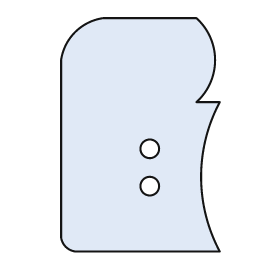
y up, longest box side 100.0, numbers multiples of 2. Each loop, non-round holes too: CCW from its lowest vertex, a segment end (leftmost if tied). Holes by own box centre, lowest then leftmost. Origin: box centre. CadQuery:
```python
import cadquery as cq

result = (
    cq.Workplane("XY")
    .moveTo(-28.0, -50.0)
    .lineTo(34.0, -50.0)
    .threePointArc((26.0, -18.0), (34.0, 14.0))
    .lineTo(24.0, 14.0)
    .threePointArc((32.0, 32.0), (24.0, 50.0))
    .lineTo(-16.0, 50.0)
    .threePointArc((-28.0, 44.0), (-34.0, 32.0))
    .lineTo(-34.0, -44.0)
    .threePointArc((-32.0, -48.0), (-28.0, -50.0))
    .close()
    .moveTo(4.0, -22.0)
    .circle(4.0)
    .moveTo(4.0, -6.0)
    .circle(4.0)
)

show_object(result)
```